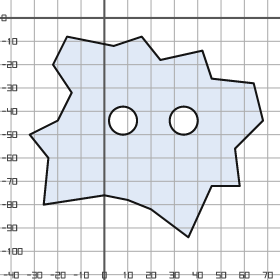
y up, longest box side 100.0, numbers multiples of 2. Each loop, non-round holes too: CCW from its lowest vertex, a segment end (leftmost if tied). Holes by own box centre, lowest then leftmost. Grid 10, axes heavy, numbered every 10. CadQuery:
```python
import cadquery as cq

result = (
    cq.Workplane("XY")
    .moveTo(36.0, -94.0)
    .lineTo(46.0, -72.0)
    .lineTo(58.0, -72.0)
    .lineTo(56.0, -56.0)
    .lineTo(68.0, -44.0)
    .lineTo(64.0, -28.0)
    .lineTo(46.0, -26.0)
    .lineTo(42.0, -14.0)
    .lineTo(24.0, -18.0)
    .lineTo(16.0, -8.0)
    .lineTo(4.0, -12.0)
    .lineTo(-16.0, -8.0)
    .lineTo(-22.0, -20.0)
    .lineTo(-14.0, -32.0)
    .lineTo(-20.0, -44.0)
    .lineTo(-32.0, -50.0)
    .lineTo(-24.0, -60.0)
    .lineTo(-26.0, -80.0)
    .lineTo(0.0, -76.0)
    .lineTo(10.0, -78.0)
    .lineTo(20.0, -82.0)
    .close()
    .moveTo(8.0, -44.0)
    .circle(6.0)
    .moveTo(34.0, -44.0)
    .circle(6.0)
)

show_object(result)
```